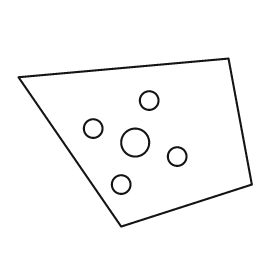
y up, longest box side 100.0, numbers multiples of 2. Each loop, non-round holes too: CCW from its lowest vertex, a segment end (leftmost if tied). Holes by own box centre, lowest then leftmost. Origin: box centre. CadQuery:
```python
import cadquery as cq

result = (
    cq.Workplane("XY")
    .moveTo(-6.0, -36.0)
    .lineTo(50.0, -18.0)
    .lineTo(40.0, 36.0)
    .lineTo(-50.0, 28.0)
    .close()
    .moveTo(-6.0, -18.0)
    .circle(4.0)
    .moveTo(18.0, -6.0)
    .circle(4.0)
    .moveTo(0.0, 0.0)
    .circle(6.0)
    .moveTo(-18.0, 6.0)
    .circle(4.0)
    .moveTo(6.0, 18.0)
    .circle(4.0)
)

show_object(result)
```